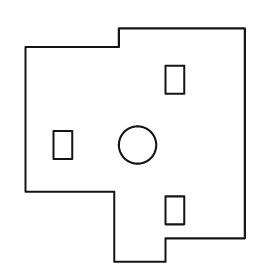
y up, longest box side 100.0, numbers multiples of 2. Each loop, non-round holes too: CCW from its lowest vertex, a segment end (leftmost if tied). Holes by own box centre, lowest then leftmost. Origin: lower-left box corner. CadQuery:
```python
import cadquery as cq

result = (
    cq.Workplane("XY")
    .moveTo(38.0, 0.0)
    .lineTo(60.0, 0.0)
    .lineTo(60.0, 10.0)
    .lineTo(94.0, 10.0)
    .lineTo(94.0, 100.0)
    .lineTo(40.0, 100.0)
    .lineTo(40.0, 92.0)
    .lineTo(0.0, 92.0)
    .lineTo(0.0, 30.0)
    .lineTo(38.0, 30.0)
    .close()
    .moveTo(60.0, 16.0)
    .lineTo(68.0, 16.0)
    .lineTo(68.0, 28.0)
    .lineTo(60.0, 28.0)
    .close()
    .moveTo(12.0, 44.0)
    .lineTo(20.0, 44.0)
    .lineTo(20.0, 56.0)
    .lineTo(12.0, 56.0)
    .close()
    .moveTo(48.0, 50.0)
    .circle(8.0)
    .moveTo(60.0, 72.0)
    .lineTo(68.0, 72.0)
    .lineTo(68.0, 84.0)
    .lineTo(60.0, 84.0)
    .close()
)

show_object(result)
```